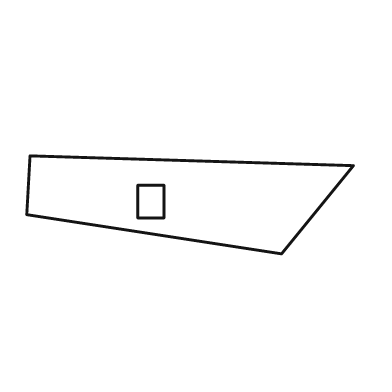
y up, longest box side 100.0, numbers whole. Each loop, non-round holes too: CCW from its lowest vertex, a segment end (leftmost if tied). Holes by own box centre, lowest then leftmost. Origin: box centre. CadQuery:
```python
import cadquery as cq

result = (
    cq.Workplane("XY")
    .moveTo(28.0, -15.0)
    .lineTo(50.0, 12.0)
    .lineTo(-49.0, 15.0)
    .lineTo(-50.0, -3.0)
    .close()
    .moveTo(-16.0, -4.0)
    .lineTo(-8.0, -4.0)
    .lineTo(-8.0, 6.0)
    .lineTo(-16.0, 6.0)
    .close()
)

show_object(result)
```